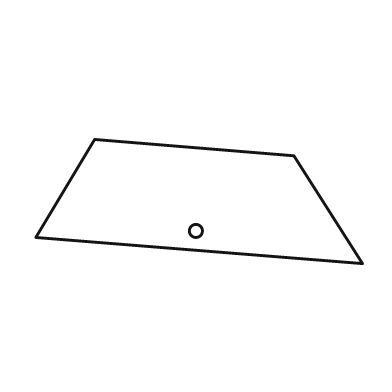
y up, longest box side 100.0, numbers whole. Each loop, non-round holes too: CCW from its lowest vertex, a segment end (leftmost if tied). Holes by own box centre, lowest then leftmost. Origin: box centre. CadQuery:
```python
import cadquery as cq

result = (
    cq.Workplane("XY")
    .moveTo(50.0, -19.0)
    .lineTo(29.0, 14.0)
    .lineTo(-32.0, 19.0)
    .lineTo(-50.0, -11.0)
    .close()
    .moveTo(-1.0, -9.0)
    .circle(2.0)
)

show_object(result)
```